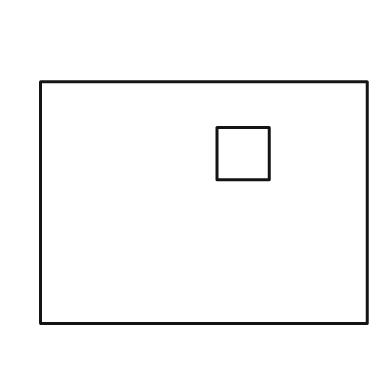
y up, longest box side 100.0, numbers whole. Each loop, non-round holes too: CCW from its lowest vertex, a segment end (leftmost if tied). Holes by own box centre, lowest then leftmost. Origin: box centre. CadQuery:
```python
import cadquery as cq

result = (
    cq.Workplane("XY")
    .moveTo(-50.0, -37.0)
    .lineTo(50.0, -37.0)
    .lineTo(50.0, 37.0)
    .lineTo(-50.0, 37.0)
    .close()
    .moveTo(4.0, 7.0)
    .lineTo(20.0, 7.0)
    .lineTo(20.0, 23.0)
    .lineTo(4.0, 23.0)
    .close()
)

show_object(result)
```